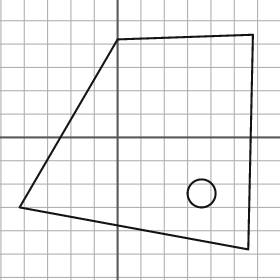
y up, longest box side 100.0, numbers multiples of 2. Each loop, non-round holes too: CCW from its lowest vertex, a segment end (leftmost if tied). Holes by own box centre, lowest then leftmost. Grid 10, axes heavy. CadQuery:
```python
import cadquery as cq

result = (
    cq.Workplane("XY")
    .moveTo(56.0, -48.0)
    .lineTo(58.0, 44.0)
    .lineTo(0.0, 42.0)
    .lineTo(-42.0, -30.0)
    .close()
    .moveTo(36.0, -24.0)
    .circle(6.0)
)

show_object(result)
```